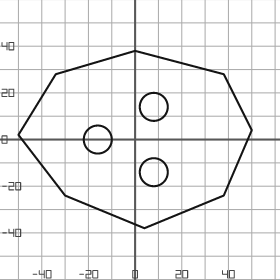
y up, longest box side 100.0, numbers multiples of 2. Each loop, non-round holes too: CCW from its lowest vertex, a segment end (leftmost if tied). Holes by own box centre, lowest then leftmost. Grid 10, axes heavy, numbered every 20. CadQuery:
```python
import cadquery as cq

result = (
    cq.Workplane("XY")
    .moveTo(4.0, -38.0)
    .lineTo(38.0, -24.0)
    .lineTo(50.0, 4.0)
    .lineTo(38.0, 28.0)
    .lineTo(0.0, 38.0)
    .lineTo(-34.0, 28.0)
    .lineTo(-50.0, 2.0)
    .lineTo(-30.0, -24.0)
    .close()
    .moveTo(8.0, -14.0)
    .circle(6.0)
    .moveTo(-16.0, 0.0)
    .circle(6.0)
    .moveTo(8.0, 14.0)
    .circle(6.0)
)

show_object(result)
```